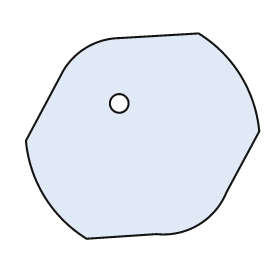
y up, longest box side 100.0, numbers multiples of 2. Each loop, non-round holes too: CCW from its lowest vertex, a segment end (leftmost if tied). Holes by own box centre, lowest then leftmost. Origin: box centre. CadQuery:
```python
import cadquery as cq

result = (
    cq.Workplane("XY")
    .moveTo(-24.0, -44.0)
    .lineTo(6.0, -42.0)
    .threePointArc((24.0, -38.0), (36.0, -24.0))
    .lineTo(50.0, 2.0)
    .threePointArc((42.0, 26.0), (24.0, 44.0))
    .lineTo(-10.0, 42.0)
    .threePointArc((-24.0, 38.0), (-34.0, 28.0))
    .lineTo(-50.0, -2.0)
    .threePointArc((-42.0, -26.0), (-24.0, -44.0))
    .close()
    .moveTo(-10.0, 14.0)
    .circle(4.0)
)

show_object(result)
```